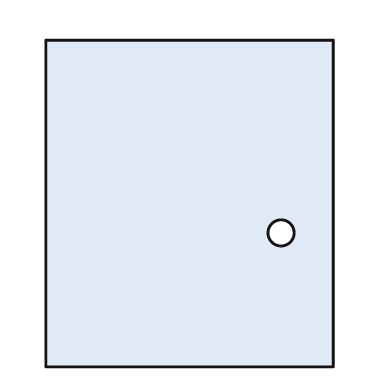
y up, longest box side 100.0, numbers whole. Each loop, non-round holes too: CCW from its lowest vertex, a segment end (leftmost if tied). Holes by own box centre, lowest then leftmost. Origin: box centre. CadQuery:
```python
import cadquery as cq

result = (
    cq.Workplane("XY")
    .moveTo(-44.0, -50.0)
    .lineTo(44.0, -50.0)
    .lineTo(44.0, 50.0)
    .lineTo(-44.0, 50.0)
    .close()
    .moveTo(28.0, -9.0)
    .circle(4.0)
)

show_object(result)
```